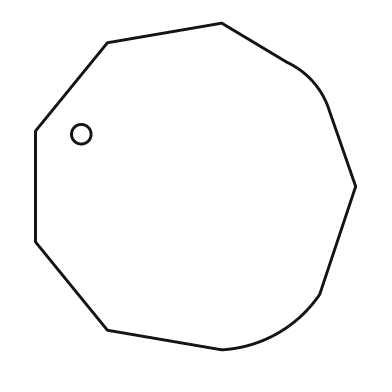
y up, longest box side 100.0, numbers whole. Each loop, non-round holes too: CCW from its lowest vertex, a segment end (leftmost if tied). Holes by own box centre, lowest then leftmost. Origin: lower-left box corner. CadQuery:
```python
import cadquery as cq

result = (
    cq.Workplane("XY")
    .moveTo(57.0, 0.0)
    .threePointArc((74.0, 5.0), (87.0, 17.0))
    .lineTo(98.0, 50.0)
    .lineTo(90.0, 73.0)
    .threePointArc((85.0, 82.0), (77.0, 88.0))
    .lineTo(57.0, 100.0)
    .lineTo(22.0, 94.0)
    .lineTo(0.0, 67.0)
    .lineTo(0.0, 33.0)
    .lineTo(22.0, 6.0)
    .close()
    .moveTo(14.0, 66.0)
    .circle(3.0)
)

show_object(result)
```